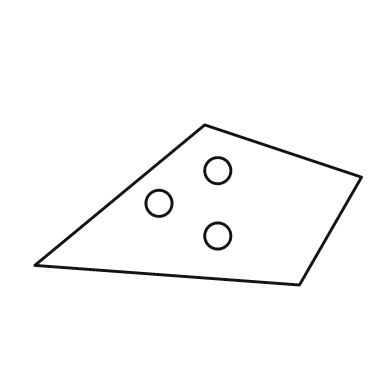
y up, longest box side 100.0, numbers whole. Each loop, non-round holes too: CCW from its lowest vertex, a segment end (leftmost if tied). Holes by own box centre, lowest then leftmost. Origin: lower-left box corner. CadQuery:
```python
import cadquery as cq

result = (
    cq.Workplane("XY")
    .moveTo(81.0, 0.0)
    .lineTo(100.0, 33.0)
    .lineTo(52.0, 49.0)
    .lineTo(0.0, 6.0)
    .close()
    .moveTo(56.0, 15.0)
    .circle(4.0)
    .moveTo(38.0, 25.0)
    .circle(4.0)
    .moveTo(56.0, 35.0)
    .circle(4.0)
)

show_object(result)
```